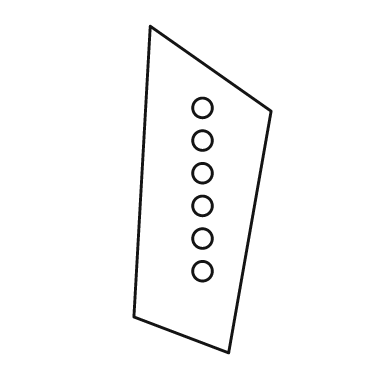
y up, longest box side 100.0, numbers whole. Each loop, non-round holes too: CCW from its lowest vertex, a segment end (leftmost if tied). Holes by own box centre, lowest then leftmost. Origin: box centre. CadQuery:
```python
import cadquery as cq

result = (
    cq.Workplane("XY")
    .moveTo(8.0, -50.0)
    .lineTo(21.0, 24.0)
    .lineTo(-16.0, 50.0)
    .lineTo(-21.0, -39.0)
    .close()
    .moveTo(0.0, -25.0)
    .circle(3.0)
    .moveTo(0.0, -15.0)
    .circle(3.0)
    .moveTo(0.0, -5.0)
    .circle(3.0)
    .moveTo(0.0, 5.0)
    .circle(3.0)
    .moveTo(0.0, 15.0)
    .circle(3.0)
    .moveTo(0.0, 25.0)
    .circle(3.0)
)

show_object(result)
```